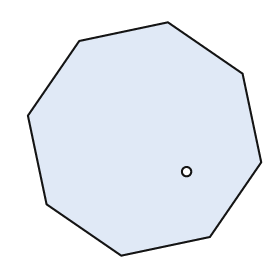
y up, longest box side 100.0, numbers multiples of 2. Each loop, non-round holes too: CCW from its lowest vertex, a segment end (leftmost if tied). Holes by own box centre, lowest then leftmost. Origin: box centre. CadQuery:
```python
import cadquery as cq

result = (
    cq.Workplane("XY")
    .moveTo(-10.0, -50.0)
    .lineTo(28.0, -42.0)
    .lineTo(50.0, -10.0)
    .lineTo(42.0, 28.0)
    .lineTo(10.0, 50.0)
    .lineTo(-28.0, 42.0)
    .lineTo(-50.0, 10.0)
    .lineTo(-42.0, -28.0)
    .close()
    .moveTo(18.0, -14.0)
    .circle(2.0)
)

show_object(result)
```